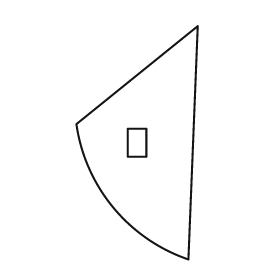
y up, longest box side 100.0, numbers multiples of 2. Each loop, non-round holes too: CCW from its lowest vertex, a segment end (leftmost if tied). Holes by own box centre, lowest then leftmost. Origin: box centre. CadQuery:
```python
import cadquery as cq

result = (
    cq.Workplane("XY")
    .moveTo(22.0, -50.0)
    .lineTo(26.0, 50.0)
    .lineTo(-26.0, 8.0)
    .threePointArc((-10.0, -28.0), (22.0, -50.0))
    .close()
    .moveTo(-4.0, -6.0)
    .lineTo(4.0, -6.0)
    .lineTo(4.0, 6.0)
    .lineTo(-4.0, 6.0)
    .close()
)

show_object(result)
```